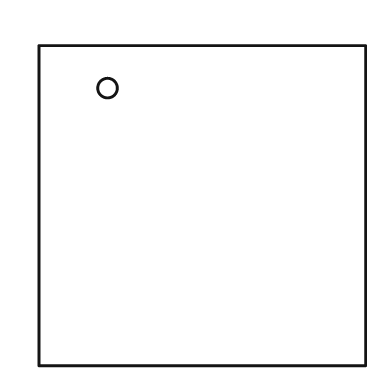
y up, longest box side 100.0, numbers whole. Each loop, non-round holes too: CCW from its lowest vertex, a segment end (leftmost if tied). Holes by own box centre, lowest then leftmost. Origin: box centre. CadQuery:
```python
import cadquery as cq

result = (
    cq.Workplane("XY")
    .moveTo(-50.0, -49.0)
    .lineTo(50.0, -49.0)
    .lineTo(50.0, 49.0)
    .lineTo(-50.0, 49.0)
    .close()
    .moveTo(-29.0, 36.0)
    .circle(3.0)
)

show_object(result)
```